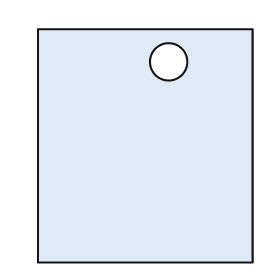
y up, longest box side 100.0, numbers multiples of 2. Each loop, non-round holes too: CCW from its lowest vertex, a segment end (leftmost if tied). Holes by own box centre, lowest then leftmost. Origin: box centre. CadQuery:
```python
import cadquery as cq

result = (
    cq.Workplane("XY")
    .moveTo(-46.0, -50.0)
    .lineTo(46.0, -50.0)
    .lineTo(46.0, 50.0)
    .lineTo(-46.0, 50.0)
    .close()
    .moveTo(10.0, 36.0)
    .circle(8.0)
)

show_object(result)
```